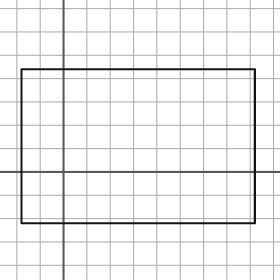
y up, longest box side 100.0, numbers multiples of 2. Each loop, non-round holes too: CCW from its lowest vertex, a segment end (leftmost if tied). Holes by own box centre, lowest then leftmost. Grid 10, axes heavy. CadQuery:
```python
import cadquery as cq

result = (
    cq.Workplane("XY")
    .moveTo(-18.0, -22.0)
    .lineTo(82.0, -22.0)
    .lineTo(82.0, 44.0)
    .lineTo(-18.0, 44.0)
    .close()
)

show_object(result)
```